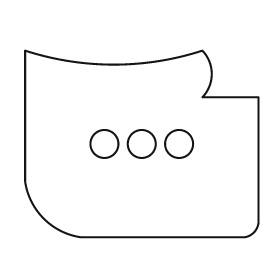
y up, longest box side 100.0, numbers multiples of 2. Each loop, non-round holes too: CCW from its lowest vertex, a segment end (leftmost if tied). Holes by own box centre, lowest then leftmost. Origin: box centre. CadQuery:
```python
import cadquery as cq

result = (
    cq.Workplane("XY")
    .moveTo(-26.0, -40.0)
    .lineTo(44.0, -40.0)
    .threePointArc((48.0, -38.0), (50.0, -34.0))
    .lineTo(50.0, 20.0)
    .lineTo(26.0, 20.0)
    .threePointArc((30.0, 30.0), (26.0, 40.0))
    .threePointArc((-12.0, 34.0), (-50.0, 40.0))
    .lineTo(-50.0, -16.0)
    .threePointArc((-42.0, -32.0), (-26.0, -40.0))
    .close()
    .moveTo(-16.0, 0.0)
    .circle(6.0)
    .moveTo(0.0, 0.0)
    .circle(6.0)
    .moveTo(16.0, 0.0)
    .circle(6.0)
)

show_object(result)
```